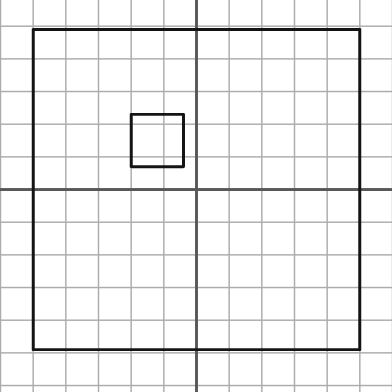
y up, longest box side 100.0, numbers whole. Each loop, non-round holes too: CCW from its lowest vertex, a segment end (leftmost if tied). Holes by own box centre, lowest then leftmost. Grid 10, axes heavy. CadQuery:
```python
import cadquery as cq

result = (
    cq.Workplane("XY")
    .moveTo(-50.0, -49.0)
    .lineTo(50.0, -49.0)
    .lineTo(50.0, 49.0)
    .lineTo(-50.0, 49.0)
    .close()
    .moveTo(-20.0, 7.0)
    .lineTo(-4.0, 7.0)
    .lineTo(-4.0, 23.0)
    .lineTo(-20.0, 23.0)
    .close()
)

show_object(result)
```